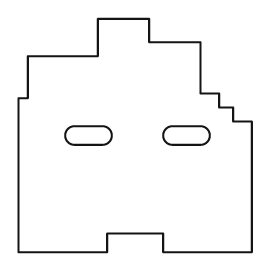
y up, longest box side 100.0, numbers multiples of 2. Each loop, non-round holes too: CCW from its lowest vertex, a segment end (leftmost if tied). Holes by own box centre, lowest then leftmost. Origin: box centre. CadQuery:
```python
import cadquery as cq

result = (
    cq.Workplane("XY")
    .moveTo(-50.0, -50.0)
    .lineTo(-12.0, -50.0)
    .lineTo(-12.0, -42.0)
    .lineTo(12.0, -42.0)
    .lineTo(12.0, -50.0)
    .lineTo(50.0, -50.0)
    .lineTo(50.0, 6.0)
    .lineTo(42.0, 6.0)
    .lineTo(42.0, 12.0)
    .lineTo(36.0, 12.0)
    .lineTo(36.0, 18.0)
    .lineTo(28.0, 18.0)
    .lineTo(28.0, 40.0)
    .lineTo(6.0, 40.0)
    .lineTo(6.0, 50.0)
    .lineTo(-16.0, 50.0)
    .lineTo(-16.0, 34.0)
    .lineTo(-46.0, 34.0)
    .lineTo(-46.0, 16.0)
    .lineTo(-50.0, 16.0)
    .close()
    .moveTo(-26.0, -4.0)
    .lineTo(-14.0, -4.0)
    .threePointArc((-10.0, 0.0), (-14.0, 4.0))
    .lineTo(-26.0, 4.0)
    .threePointArc((-30.0, 0.0), (-26.0, -4.0))
    .close()
    .moveTo(16.0, -4.0)
    .lineTo(28.0, -4.0)
    .threePointArc((32.0, 0.0), (28.0, 4.0))
    .lineTo(16.0, 4.0)
    .threePointArc((12.0, 0.0), (16.0, -4.0))
    .close()
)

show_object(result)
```